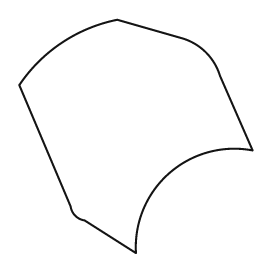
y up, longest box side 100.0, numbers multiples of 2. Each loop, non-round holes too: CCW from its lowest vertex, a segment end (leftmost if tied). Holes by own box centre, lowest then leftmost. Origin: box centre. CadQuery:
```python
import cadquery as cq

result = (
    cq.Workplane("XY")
    .moveTo(0.0, -50.0)
    .threePointArc((14.0, -16.0), (50.0, -6.0))
    .lineTo(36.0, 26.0)
    .threePointArc((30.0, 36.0), (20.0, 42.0))
    .lineTo(-8.0, 50.0)
    .threePointArc((-32.0, 40.0), (-50.0, 22.0))
    .lineTo(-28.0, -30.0)
    .threePointArc((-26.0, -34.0), (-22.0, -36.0))
    .close()
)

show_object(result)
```